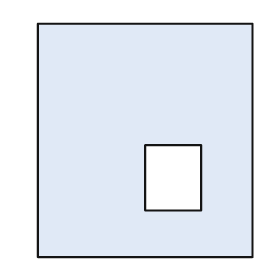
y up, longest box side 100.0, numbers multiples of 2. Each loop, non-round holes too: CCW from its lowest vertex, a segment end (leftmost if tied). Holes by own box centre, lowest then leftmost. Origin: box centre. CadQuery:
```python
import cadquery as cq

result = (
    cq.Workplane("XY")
    .moveTo(-46.0, -50.0)
    .lineTo(46.0, -50.0)
    .lineTo(46.0, 50.0)
    .lineTo(-46.0, 50.0)
    .close()
    .moveTo(0.0, -30.0)
    .lineTo(24.0, -30.0)
    .lineTo(24.0, -2.0)
    .lineTo(0.0, -2.0)
    .close()
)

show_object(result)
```